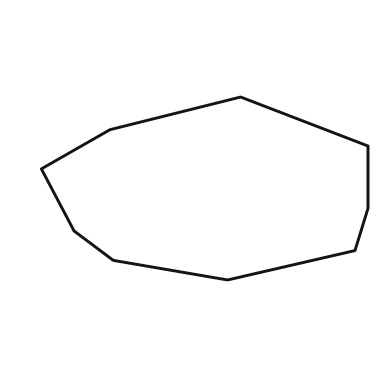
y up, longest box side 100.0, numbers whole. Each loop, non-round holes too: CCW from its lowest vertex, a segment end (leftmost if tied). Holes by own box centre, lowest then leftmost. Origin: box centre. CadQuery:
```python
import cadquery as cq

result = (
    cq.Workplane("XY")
    .moveTo(7.0, -28.0)
    .lineTo(46.0, -19.0)
    .lineTo(50.0, -6.0)
    .lineTo(50.0, 13.0)
    .lineTo(11.0, 28.0)
    .lineTo(-29.0, 18.0)
    .lineTo(-50.0, 6.0)
    .lineTo(-40.0, -13.0)
    .lineTo(-28.0, -22.0)
    .close()
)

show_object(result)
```